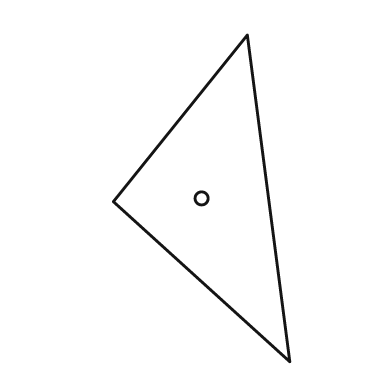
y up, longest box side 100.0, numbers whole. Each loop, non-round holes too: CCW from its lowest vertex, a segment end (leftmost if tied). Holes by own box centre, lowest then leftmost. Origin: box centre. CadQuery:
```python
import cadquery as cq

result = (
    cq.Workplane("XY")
    .moveTo(27.0, -50.0)
    .lineTo(14.0, 50.0)
    .lineTo(-27.0, -1.0)
    .close()
    .moveTo(0.0, 0.0)
    .circle(2.0)
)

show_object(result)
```